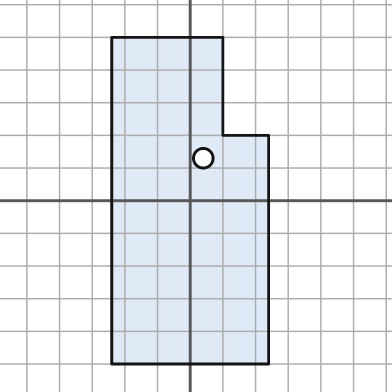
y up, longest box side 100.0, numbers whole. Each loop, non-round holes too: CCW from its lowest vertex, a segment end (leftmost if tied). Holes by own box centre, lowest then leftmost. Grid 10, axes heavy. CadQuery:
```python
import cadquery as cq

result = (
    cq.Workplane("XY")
    .moveTo(-24.0, -50.0)
    .lineTo(24.0, -50.0)
    .lineTo(24.0, 20.0)
    .lineTo(10.0, 20.0)
    .lineTo(10.0, 50.0)
    .lineTo(-24.0, 50.0)
    .close()
    .moveTo(4.0, 13.0)
    .circle(3.0)
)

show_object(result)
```